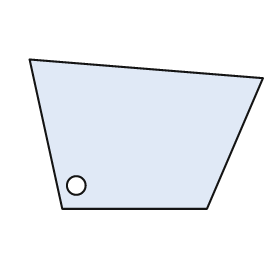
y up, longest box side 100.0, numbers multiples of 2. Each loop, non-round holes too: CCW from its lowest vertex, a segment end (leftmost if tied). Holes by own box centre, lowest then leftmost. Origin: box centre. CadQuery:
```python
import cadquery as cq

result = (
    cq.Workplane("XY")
    .moveTo(-36.0, -32.0)
    .lineTo(26.0, -32.0)
    .lineTo(50.0, 24.0)
    .lineTo(-50.0, 32.0)
    .close()
    .moveTo(-30.0, -22.0)
    .circle(4.0)
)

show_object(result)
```